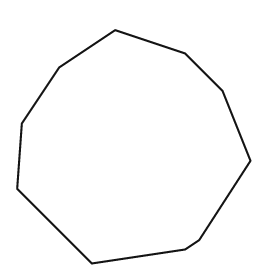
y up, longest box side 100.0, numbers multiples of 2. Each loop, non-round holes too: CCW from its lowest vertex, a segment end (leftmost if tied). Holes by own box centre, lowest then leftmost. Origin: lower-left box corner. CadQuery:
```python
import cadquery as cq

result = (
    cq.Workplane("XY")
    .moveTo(32.0, 0.0)
    .lineTo(72.0, 6.0)
    .lineTo(78.0, 10.0)
    .lineTo(100.0, 44.0)
    .lineTo(88.0, 74.0)
    .lineTo(72.0, 90.0)
    .lineTo(42.0, 100.0)
    .lineTo(18.0, 84.0)
    .lineTo(2.0, 60.0)
    .lineTo(0.0, 32.0)
    .close()
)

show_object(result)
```